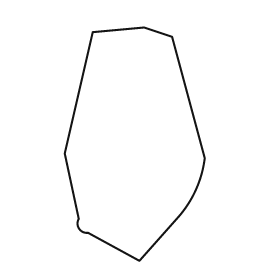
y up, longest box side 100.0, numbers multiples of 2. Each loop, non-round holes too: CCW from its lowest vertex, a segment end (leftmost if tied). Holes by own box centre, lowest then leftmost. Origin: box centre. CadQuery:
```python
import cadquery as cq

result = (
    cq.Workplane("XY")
    .moveTo(2.0, -50.0)
    .lineTo(18.0, -32.0)
    .threePointArc((26.0, -20.0), (30.0, -6.0))
    .lineTo(16.0, 46.0)
    .lineTo(4.0, 50.0)
    .lineTo(-18.0, 48.0)
    .lineTo(-30.0, -4.0)
    .lineTo(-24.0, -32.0)
    .threePointArc((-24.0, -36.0), (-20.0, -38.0))
    .close()
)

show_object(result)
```